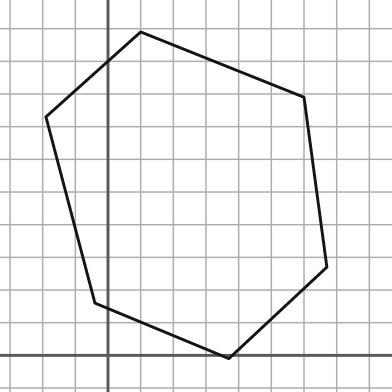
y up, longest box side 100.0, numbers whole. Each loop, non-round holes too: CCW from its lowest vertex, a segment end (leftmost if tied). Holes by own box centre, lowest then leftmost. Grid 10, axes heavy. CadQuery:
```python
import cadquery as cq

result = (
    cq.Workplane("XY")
    .moveTo(37.0, -1.0)
    .lineTo(67.0, 27.0)
    .lineTo(60.0, 79.0)
    .lineTo(10.0, 99.0)
    .lineTo(-19.0, 73.0)
    .lineTo(-4.0, 16.0)
    .close()
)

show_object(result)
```